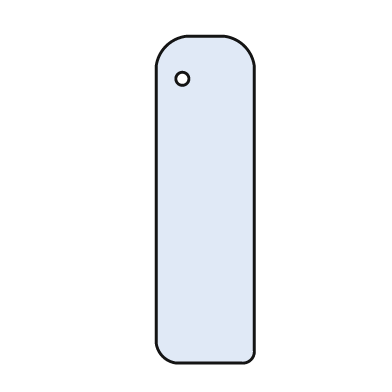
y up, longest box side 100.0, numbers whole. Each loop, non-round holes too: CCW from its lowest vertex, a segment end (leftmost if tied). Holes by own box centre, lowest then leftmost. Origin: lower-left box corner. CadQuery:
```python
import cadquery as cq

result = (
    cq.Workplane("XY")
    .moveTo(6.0, 0.0)
    .lineTo(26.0, 0.0)
    .threePointArc((29.0, 1.0), (30.0, 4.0))
    .lineTo(30.0, 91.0)
    .threePointArc((27.0, 97.0), (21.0, 100.0))
    .lineTo(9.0, 100.0)
    .threePointArc((3.0, 97.0), (0.0, 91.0))
    .lineTo(0.0, 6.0)
    .threePointArc((2.0, 2.0), (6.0, 0.0))
    .close()
    .moveTo(8.0, 87.0)
    .circle(2.0)
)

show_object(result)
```